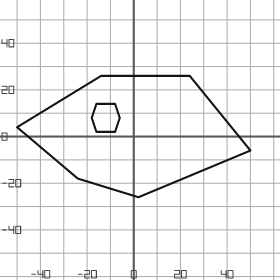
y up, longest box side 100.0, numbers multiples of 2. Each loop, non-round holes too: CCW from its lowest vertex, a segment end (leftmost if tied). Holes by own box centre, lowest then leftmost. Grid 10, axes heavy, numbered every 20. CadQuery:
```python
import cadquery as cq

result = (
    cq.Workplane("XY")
    .moveTo(2.0, -26.0)
    .lineTo(50.0, -6.0)
    .lineTo(24.0, 26.0)
    .lineTo(-14.0, 26.0)
    .lineTo(-50.0, 4.0)
    .lineTo(-24.0, -18.0)
    .close()
    .moveTo(-16.0, 2.0)
    .lineTo(-8.0, 2.0)
    .lineTo(-6.0, 8.0)
    .lineTo(-8.0, 14.0)
    .lineTo(-16.0, 14.0)
    .lineTo(-18.0, 8.0)
    .close()
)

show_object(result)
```